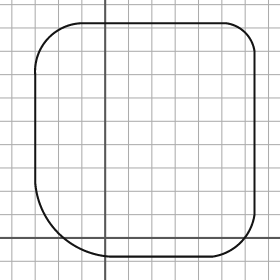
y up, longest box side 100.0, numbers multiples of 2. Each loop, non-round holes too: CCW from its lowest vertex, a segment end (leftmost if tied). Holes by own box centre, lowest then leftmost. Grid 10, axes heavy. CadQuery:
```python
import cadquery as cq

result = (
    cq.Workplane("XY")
    .moveTo(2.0, -8.0)
    .lineTo(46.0, -8.0)
    .threePointArc((58.0, -2.0), (64.0, 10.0))
    .lineTo(64.0, 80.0)
    .threePointArc((60.0, 88.0), (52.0, 92.0))
    .lineTo(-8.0, 92.0)
    .threePointArc((-24.0, 86.0), (-30.0, 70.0))
    .lineTo(-30.0, 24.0)
    .threePointArc((-20.0, 2.0), (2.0, -8.0))
    .close()
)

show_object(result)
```